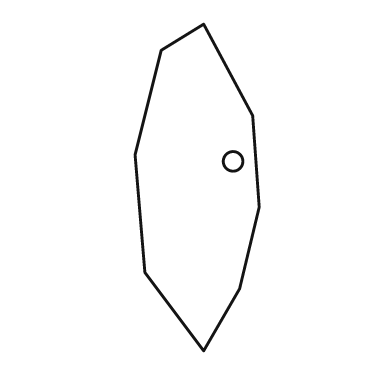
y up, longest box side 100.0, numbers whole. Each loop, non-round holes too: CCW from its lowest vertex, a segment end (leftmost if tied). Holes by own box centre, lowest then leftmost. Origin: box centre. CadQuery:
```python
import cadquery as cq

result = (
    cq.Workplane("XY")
    .moveTo(2.0, -50.0)
    .lineTo(13.0, -31.0)
    .lineTo(19.0, -6.0)
    .lineTo(17.0, 22.0)
    .lineTo(2.0, 50.0)
    .lineTo(-11.0, 42.0)
    .lineTo(-19.0, 10.0)
    .lineTo(-16.0, -26.0)
    .close()
    .moveTo(11.0, 8.0)
    .circle(3.0)
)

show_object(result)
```